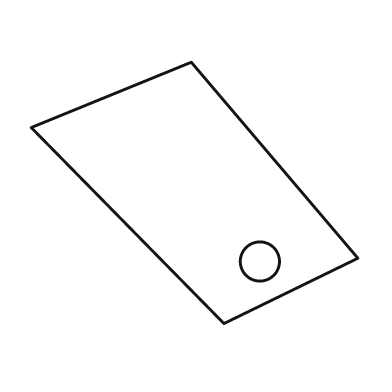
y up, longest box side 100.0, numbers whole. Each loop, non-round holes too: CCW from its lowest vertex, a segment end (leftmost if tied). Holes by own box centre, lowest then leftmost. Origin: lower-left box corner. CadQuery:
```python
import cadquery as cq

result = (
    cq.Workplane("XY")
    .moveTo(59.0, 0.0)
    .lineTo(100.0, 20.0)
    .lineTo(49.0, 80.0)
    .lineTo(0.0, 60.0)
    .close()
    .moveTo(70.0, 19.0)
    .circle(6.0)
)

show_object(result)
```